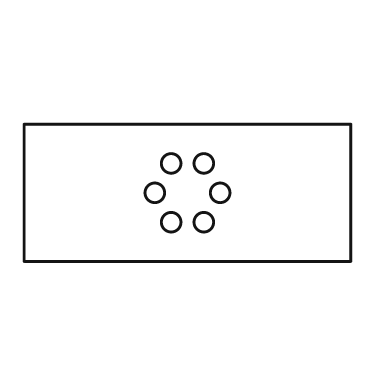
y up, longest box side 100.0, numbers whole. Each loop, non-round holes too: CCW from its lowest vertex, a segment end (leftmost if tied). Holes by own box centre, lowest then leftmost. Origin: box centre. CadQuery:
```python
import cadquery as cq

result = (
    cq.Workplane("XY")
    .moveTo(-50.0, -21.0)
    .lineTo(50.0, -21.0)
    .lineTo(50.0, 21.0)
    .lineTo(-50.0, 21.0)
    .close()
    .moveTo(-5.0, -9.0)
    .circle(3.0)
    .moveTo(5.0, -9.0)
    .circle(3.0)
    .moveTo(-10.0, 0.0)
    .circle(3.0)
    .moveTo(10.0, 0.0)
    .circle(3.0)
    .moveTo(-5.0, 9.0)
    .circle(3.0)
    .moveTo(5.0, 9.0)
    .circle(3.0)
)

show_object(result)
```